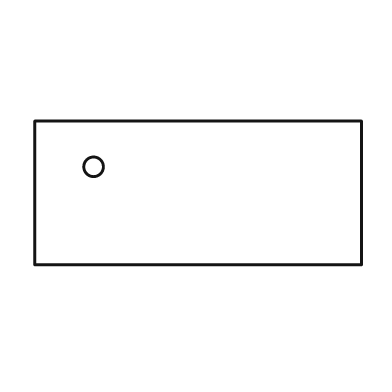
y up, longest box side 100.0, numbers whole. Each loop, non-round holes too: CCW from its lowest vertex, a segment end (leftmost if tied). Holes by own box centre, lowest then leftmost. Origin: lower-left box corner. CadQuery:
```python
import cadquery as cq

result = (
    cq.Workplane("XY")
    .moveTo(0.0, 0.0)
    .lineTo(100.0, 0.0)
    .lineTo(100.0, 44.0)
    .lineTo(0.0, 44.0)
    .close()
    .moveTo(18.0, 30.0)
    .circle(3.0)
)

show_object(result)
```